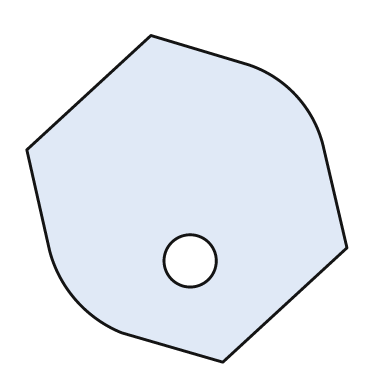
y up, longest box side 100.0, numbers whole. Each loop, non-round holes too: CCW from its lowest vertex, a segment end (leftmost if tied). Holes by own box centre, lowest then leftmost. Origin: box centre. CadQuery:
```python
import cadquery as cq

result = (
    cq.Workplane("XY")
    .moveTo(11.0, -50.0)
    .lineTo(49.0, -15.0)
    .lineTo(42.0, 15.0)
    .threePointArc((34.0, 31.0), (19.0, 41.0))
    .lineTo(-11.0, 50.0)
    .lineTo(-49.0, 15.0)
    .lineTo(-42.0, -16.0)
    .threePointArc((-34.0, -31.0), (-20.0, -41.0))
    .close()
    .moveTo(1.0, -19.0)
    .circle(8.0)
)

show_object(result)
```